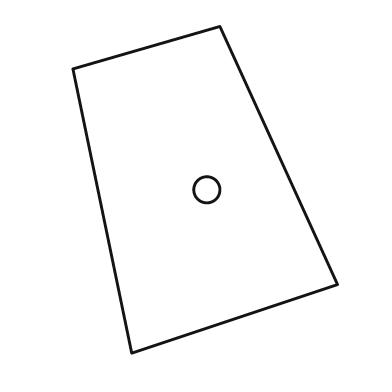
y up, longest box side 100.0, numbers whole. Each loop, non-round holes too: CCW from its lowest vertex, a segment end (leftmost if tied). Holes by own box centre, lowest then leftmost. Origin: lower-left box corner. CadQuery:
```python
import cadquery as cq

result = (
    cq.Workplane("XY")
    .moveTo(18.0, 0.0)
    .lineTo(81.0, 21.0)
    .lineTo(45.0, 100.0)
    .lineTo(0.0, 87.0)
    .close()
    .moveTo(41.0, 50.0)
    .circle(4.0)
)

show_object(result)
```